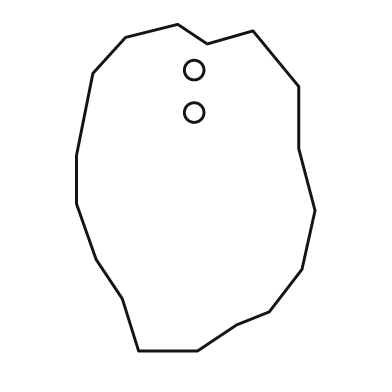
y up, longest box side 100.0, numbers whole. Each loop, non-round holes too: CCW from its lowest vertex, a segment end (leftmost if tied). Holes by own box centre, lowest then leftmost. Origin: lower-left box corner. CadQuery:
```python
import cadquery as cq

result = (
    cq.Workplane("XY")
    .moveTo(19.0, 0.0)
    .lineTo(37.0, 0.0)
    .lineTo(49.0, 8.0)
    .lineTo(59.0, 12.0)
    .lineTo(69.0, 25.0)
    .lineTo(73.0, 43.0)
    .lineTo(68.0, 62.0)
    .lineTo(68.0, 81.0)
    .lineTo(54.0, 98.0)
    .lineTo(40.0, 94.0)
    .lineTo(31.0, 100.0)
    .lineTo(15.0, 96.0)
    .lineTo(5.0, 85.0)
    .lineTo(0.0, 60.0)
    .lineTo(0.0, 45.0)
    .lineTo(6.0, 28.0)
    .lineTo(14.0, 16.0)
    .close()
    .moveTo(36.0, 73.0)
    .circle(3.0)
    .moveTo(36.0, 86.0)
    .circle(3.0)
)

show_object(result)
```